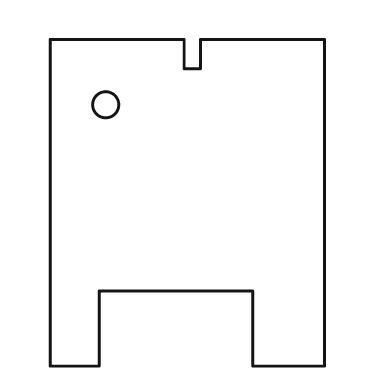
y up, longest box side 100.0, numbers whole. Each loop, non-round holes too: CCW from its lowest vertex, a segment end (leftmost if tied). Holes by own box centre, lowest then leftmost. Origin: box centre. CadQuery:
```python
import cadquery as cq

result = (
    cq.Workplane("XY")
    .moveTo(-42.0, -50.0)
    .lineTo(-27.0, -50.0)
    .lineTo(-27.0, -27.0)
    .lineTo(20.0, -27.0)
    .lineTo(20.0, -50.0)
    .lineTo(42.0, -50.0)
    .lineTo(42.0, 50.0)
    .lineTo(4.0, 50.0)
    .lineTo(4.0, 41.0)
    .lineTo(-1.0, 41.0)
    .lineTo(-1.0, 50.0)
    .lineTo(-42.0, 50.0)
    .close()
    .moveTo(-25.0, 30.0)
    .circle(4.0)
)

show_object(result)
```